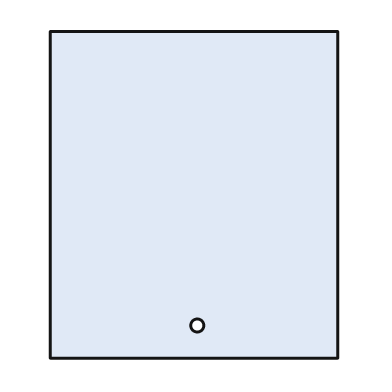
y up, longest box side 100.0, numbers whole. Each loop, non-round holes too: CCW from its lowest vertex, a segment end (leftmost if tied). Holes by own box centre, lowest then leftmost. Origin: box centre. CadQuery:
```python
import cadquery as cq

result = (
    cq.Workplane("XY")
    .moveTo(-44.0, -50.0)
    .lineTo(44.0, -50.0)
    .lineTo(44.0, 50.0)
    .lineTo(-44.0, 50.0)
    .close()
    .moveTo(1.0, -40.0)
    .circle(2.0)
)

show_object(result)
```